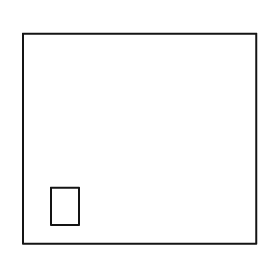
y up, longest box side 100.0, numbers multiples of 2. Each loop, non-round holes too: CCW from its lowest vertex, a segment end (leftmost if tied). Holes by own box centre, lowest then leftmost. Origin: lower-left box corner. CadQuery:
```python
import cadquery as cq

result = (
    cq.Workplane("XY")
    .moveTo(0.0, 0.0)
    .lineTo(100.0, 0.0)
    .lineTo(100.0, 90.0)
    .lineTo(0.0, 90.0)
    .close()
    .moveTo(12.0, 8.0)
    .lineTo(24.0, 8.0)
    .lineTo(24.0, 24.0)
    .lineTo(12.0, 24.0)
    .close()
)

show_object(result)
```